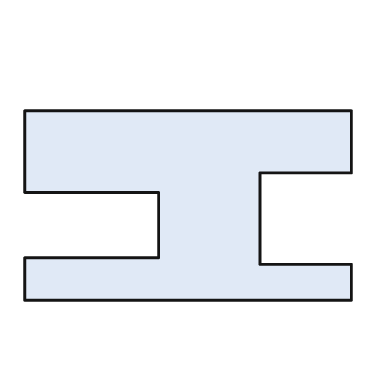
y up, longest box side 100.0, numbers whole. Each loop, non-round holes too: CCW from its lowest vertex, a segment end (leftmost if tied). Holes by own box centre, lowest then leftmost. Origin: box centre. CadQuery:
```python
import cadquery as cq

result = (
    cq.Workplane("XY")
    .moveTo(-50.0, -29.0)
    .lineTo(50.0, -29.0)
    .lineTo(50.0, -18.0)
    .lineTo(22.0, -18.0)
    .lineTo(22.0, 10.0)
    .lineTo(50.0, 10.0)
    .lineTo(50.0, 29.0)
    .lineTo(-50.0, 29.0)
    .lineTo(-50.0, 4.0)
    .lineTo(-9.0, 4.0)
    .lineTo(-9.0, -16.0)
    .lineTo(-50.0, -16.0)
    .close()
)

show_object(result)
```